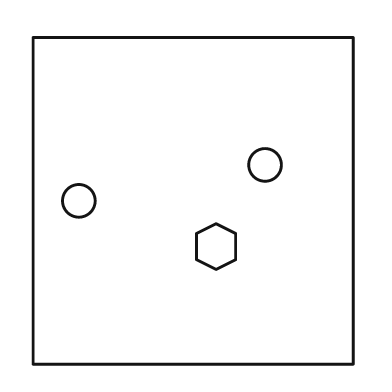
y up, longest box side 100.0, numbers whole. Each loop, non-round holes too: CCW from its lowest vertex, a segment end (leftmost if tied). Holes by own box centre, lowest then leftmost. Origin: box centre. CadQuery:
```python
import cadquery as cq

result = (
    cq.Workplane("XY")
    .moveTo(-49.0, -50.0)
    .lineTo(49.0, -50.0)
    .lineTo(49.0, 50.0)
    .lineTo(-49.0, 50.0)
    .close()
    .moveTo(7.0, -21.0)
    .lineTo(13.0, -18.0)
    .lineTo(13.0, -10.0)
    .lineTo(7.0, -7.0)
    .lineTo(1.0, -10.0)
    .lineTo(1.0, -18.0)
    .close()
    .moveTo(-35.0, 0.0)
    .circle(5.0)
    .moveTo(22.0, 11.0)
    .circle(5.0)
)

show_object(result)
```